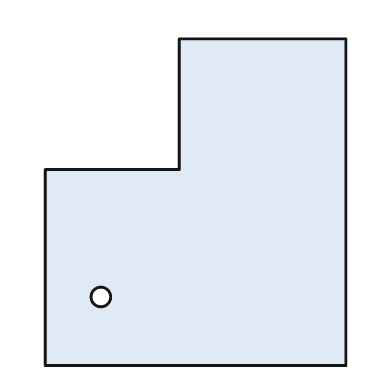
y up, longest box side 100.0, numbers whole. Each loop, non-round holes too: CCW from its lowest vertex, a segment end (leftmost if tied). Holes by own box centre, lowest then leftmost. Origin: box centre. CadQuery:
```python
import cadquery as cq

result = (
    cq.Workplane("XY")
    .moveTo(-46.0, -50.0)
    .lineTo(46.0, -50.0)
    .lineTo(46.0, 50.0)
    .lineTo(-5.0, 50.0)
    .lineTo(-5.0, 10.0)
    .lineTo(-46.0, 10.0)
    .close()
    .moveTo(-29.0, -29.0)
    .circle(3.0)
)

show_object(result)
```